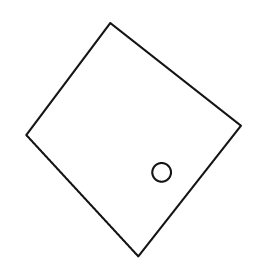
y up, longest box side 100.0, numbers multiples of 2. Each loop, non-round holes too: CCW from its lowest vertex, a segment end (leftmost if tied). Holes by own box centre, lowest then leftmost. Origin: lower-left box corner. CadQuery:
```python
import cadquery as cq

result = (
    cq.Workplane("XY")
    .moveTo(48.0, 0.0)
    .lineTo(92.0, 56.0)
    .lineTo(36.0, 100.0)
    .lineTo(0.0, 52.0)
    .close()
    .moveTo(58.0, 36.0)
    .circle(4.0)
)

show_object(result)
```